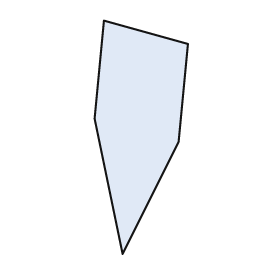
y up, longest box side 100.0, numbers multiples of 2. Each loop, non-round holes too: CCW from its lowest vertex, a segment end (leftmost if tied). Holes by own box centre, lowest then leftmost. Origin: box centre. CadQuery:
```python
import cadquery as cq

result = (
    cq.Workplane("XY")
    .moveTo(-8.0, -50.0)
    .lineTo(16.0, -2.0)
    .lineTo(20.0, 40.0)
    .lineTo(-16.0, 50.0)
    .lineTo(-20.0, 8.0)
    .close()
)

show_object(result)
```